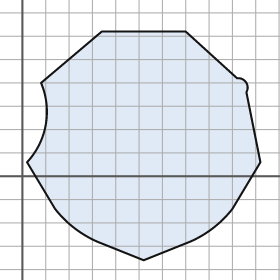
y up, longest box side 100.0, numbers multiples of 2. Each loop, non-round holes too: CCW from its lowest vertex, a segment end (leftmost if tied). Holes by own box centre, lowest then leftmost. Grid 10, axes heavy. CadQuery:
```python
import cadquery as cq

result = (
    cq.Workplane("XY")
    .moveTo(52.0, -36.0)
    .lineTo(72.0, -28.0)
    .threePointArc((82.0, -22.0), (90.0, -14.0))
    .lineTo(102.0, 6.0)
    .lineTo(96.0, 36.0)
    .threePointArc((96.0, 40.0), (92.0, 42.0))
    .lineTo(70.0, 62.0)
    .lineTo(34.0, 62.0)
    .lineTo(8.0, 40.0)
    .threePointArc((10.0, 22.0), (2.0, 6.0))
    .lineTo(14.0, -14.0)
    .threePointArc((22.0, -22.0), (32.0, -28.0))
    .close()
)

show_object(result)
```